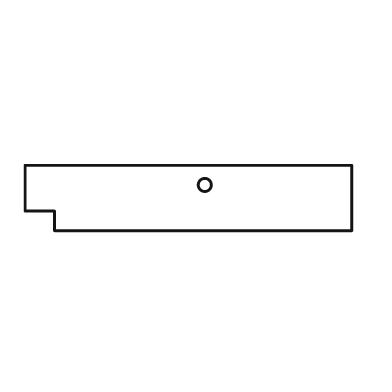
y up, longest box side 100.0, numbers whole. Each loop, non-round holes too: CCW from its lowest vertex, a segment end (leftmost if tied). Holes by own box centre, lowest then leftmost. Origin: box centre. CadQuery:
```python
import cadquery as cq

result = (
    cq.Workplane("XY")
    .moveTo(-41.0, -10.0)
    .lineTo(50.0, -10.0)
    .lineTo(50.0, 10.0)
    .lineTo(-50.0, 10.0)
    .lineTo(-50.0, -4.0)
    .lineTo(-41.0, -4.0)
    .close()
    .moveTo(5.0, 4.0)
    .circle(2.0)
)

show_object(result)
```